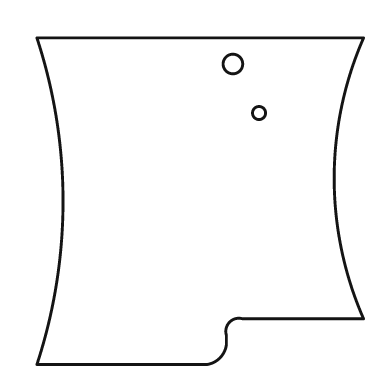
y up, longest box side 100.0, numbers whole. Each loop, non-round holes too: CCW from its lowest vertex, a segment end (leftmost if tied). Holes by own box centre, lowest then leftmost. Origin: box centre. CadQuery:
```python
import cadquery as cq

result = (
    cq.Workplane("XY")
    .moveTo(-50.0, -50.0)
    .lineTo(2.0, -50.0)
    .threePointArc((6.0, -48.0), (8.0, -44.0))
    .lineTo(8.0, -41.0)
    .threePointArc((9.0, -37.0), (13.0, -36.0))
    .lineTo(50.0, -36.0)
    .threePointArc((41.0, 7.0), (50.0, 50.0))
    .lineTo(-50.0, 50.0)
    .threePointArc((-42.0, 0.0), (-50.0, -50.0))
    .close()
    .moveTo(18.0, 27.0)
    .circle(2.0)
    .moveTo(10.0, 42.0)
    .circle(3.0)
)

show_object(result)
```